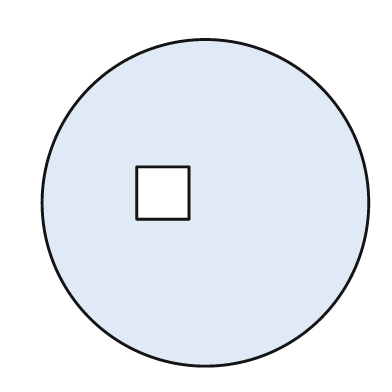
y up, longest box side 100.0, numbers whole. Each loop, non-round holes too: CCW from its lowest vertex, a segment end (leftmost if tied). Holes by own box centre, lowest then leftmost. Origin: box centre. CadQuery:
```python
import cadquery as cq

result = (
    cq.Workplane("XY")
    .moveTo(0.0, 0.0)
    .circle(50.0)
    .moveTo(-21.0, -5.0)
    .lineTo(-5.0, -5.0)
    .lineTo(-5.0, 11.0)
    .lineTo(-21.0, 11.0)
    .close()
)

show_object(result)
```